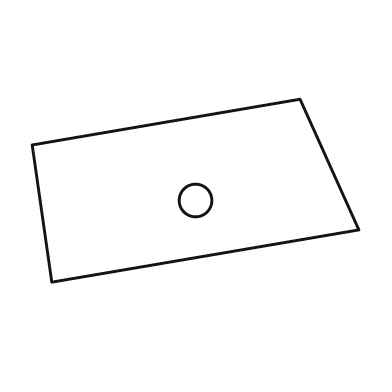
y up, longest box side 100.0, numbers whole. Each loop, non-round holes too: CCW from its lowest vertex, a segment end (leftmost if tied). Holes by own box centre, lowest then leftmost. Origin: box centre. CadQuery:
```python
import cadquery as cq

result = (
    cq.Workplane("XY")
    .moveTo(-44.0, -28.0)
    .lineTo(50.0, -12.0)
    .lineTo(32.0, 28.0)
    .lineTo(-50.0, 14.0)
    .close()
    .moveTo(0.0, -3.0)
    .circle(5.0)
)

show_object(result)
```